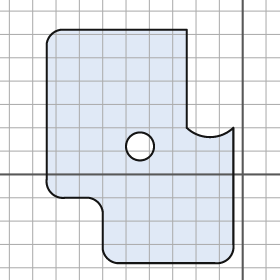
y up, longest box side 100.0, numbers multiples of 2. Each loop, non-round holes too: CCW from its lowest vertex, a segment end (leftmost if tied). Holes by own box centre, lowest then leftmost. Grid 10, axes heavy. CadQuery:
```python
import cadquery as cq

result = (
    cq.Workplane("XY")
    .moveTo(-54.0, -38.0)
    .lineTo(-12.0, -38.0)
    .threePointArc((-6.0, -36.0), (-4.0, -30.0))
    .lineTo(-4.0, 20.0)
    .threePointArc((-14.0, 16.0), (-24.0, 20.0))
    .lineTo(-24.0, 62.0)
    .lineTo(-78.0, 62.0)
    .threePointArc((-82.0, 60.0), (-84.0, 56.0))
    .lineTo(-84.0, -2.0)
    .threePointArc((-82.0, -8.0), (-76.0, -10.0))
    .lineTo(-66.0, -10.0)
    .threePointArc((-62.0, -12.0), (-60.0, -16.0))
    .lineTo(-60.0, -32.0)
    .threePointArc((-58.0, -36.0), (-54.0, -38.0))
    .close()
    .moveTo(-44.0, 12.0)
    .circle(6.0)
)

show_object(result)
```